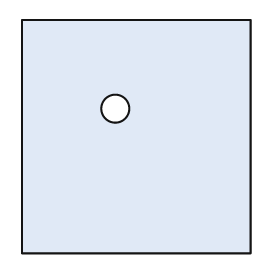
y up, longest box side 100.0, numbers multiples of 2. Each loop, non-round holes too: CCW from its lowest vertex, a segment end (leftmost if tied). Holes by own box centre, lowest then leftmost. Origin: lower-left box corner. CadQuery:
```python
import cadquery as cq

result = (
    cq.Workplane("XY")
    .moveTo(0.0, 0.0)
    .lineTo(98.0, 0.0)
    .lineTo(98.0, 100.0)
    .lineTo(0.0, 100.0)
    .close()
    .moveTo(40.0, 62.0)
    .circle(6.0)
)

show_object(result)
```